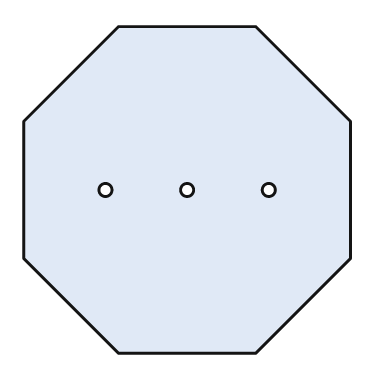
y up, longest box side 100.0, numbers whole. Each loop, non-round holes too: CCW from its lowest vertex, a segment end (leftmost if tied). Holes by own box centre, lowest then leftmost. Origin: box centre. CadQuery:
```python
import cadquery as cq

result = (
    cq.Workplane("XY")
    .moveTo(-21.0, -50.0)
    .lineTo(21.0, -50.0)
    .lineTo(50.0, -21.0)
    .lineTo(50.0, 21.0)
    .lineTo(21.0, 50.0)
    .lineTo(-21.0, 50.0)
    .lineTo(-50.0, 21.0)
    .lineTo(-50.0, -21.0)
    .close()
    .moveTo(-25.0, 0.0)
    .circle(2.0)
    .moveTo(0.0, 0.0)
    .circle(2.0)
    .moveTo(25.0, 0.0)
    .circle(2.0)
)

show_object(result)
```